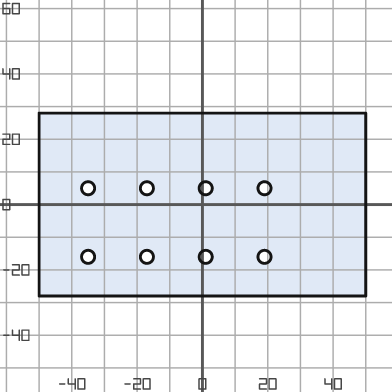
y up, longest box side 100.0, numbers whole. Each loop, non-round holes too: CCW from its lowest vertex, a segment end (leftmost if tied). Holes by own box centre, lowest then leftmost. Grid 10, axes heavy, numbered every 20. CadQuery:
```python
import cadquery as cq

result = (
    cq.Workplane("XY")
    .moveTo(-50.0, -28.0)
    .lineTo(50.0, -28.0)
    .lineTo(50.0, 28.0)
    .lineTo(-50.0, 28.0)
    .close()
    .moveTo(-35.0, -16.0)
    .circle(2.0)
    .moveTo(-17.0, -16.0)
    .circle(2.0)
    .moveTo(1.0, -16.0)
    .circle(2.0)
    .moveTo(19.0, -16.0)
    .circle(2.0)
    .moveTo(-35.0, 5.0)
    .circle(2.0)
    .moveTo(-17.0, 5.0)
    .circle(2.0)
    .moveTo(1.0, 5.0)
    .circle(2.0)
    .moveTo(19.0, 5.0)
    .circle(2.0)
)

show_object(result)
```